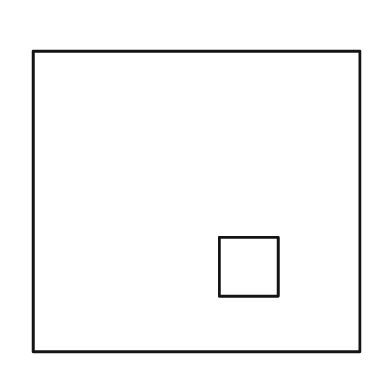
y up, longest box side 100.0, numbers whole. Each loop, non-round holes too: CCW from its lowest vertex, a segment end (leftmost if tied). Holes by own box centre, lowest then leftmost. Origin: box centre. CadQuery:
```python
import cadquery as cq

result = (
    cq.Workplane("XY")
    .moveTo(-50.0, -46.0)
    .lineTo(50.0, -46.0)
    .lineTo(50.0, 46.0)
    .lineTo(-50.0, 46.0)
    .close()
    .moveTo(7.0, -29.0)
    .lineTo(25.0, -29.0)
    .lineTo(25.0, -11.0)
    .lineTo(7.0, -11.0)
    .close()
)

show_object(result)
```